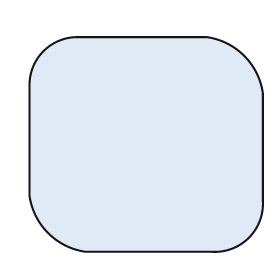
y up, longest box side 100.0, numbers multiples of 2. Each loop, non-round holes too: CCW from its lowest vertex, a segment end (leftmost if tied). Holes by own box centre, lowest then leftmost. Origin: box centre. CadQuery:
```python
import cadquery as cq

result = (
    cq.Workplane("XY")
    .moveTo(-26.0, -46.0)
    .lineTo(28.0, -46.0)
    .threePointArc((44.0, -40.0), (50.0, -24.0))
    .lineTo(50.0, 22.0)
    .threePointArc((42.0, 38.0), (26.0, 46.0))
    .lineTo(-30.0, 46.0)
    .threePointArc((-44.0, 40.0), (-50.0, 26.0))
    .lineTo(-50.0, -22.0)
    .threePointArc((-42.0, -38.0), (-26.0, -46.0))
    .close()
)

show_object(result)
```